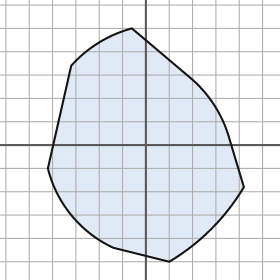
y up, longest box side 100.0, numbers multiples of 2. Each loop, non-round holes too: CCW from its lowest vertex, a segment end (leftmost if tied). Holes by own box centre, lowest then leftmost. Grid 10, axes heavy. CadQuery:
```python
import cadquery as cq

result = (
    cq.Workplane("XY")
    .moveTo(10.0, -50.0)
    .threePointArc((28.0, -36.0), (42.0, -18.0))
    .lineTo(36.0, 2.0)
    .threePointArc((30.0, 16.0), (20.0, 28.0))
    .lineTo(-6.0, 50.0)
    .threePointArc((-20.0, 44.0), (-32.0, 34.0))
    .lineTo(-42.0, -10.0)
    .threePointArc((-32.0, -30.0), (-14.0, -44.0))
    .close()
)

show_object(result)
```